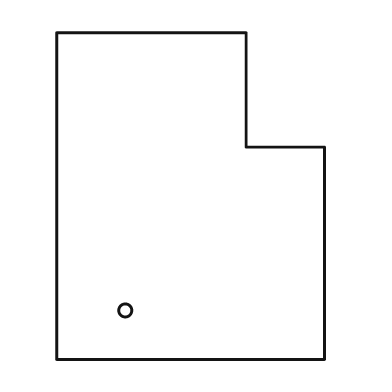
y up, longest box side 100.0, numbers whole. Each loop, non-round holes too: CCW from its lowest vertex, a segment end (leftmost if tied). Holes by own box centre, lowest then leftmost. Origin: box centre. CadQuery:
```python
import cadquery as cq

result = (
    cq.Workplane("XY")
    .moveTo(-41.0, -50.0)
    .lineTo(41.0, -50.0)
    .lineTo(41.0, 15.0)
    .lineTo(17.0, 15.0)
    .lineTo(17.0, 50.0)
    .lineTo(-41.0, 50.0)
    .close()
    .moveTo(-20.0, -35.0)
    .circle(2.0)
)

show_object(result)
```